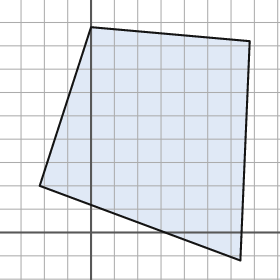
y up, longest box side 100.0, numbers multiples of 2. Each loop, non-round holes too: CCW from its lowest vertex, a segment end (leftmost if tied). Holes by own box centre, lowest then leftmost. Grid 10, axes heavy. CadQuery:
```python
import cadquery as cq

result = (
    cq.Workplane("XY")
    .moveTo(64.0, -12.0)
    .lineTo(68.0, 82.0)
    .lineTo(0.0, 88.0)
    .lineTo(-22.0, 20.0)
    .close()
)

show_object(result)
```